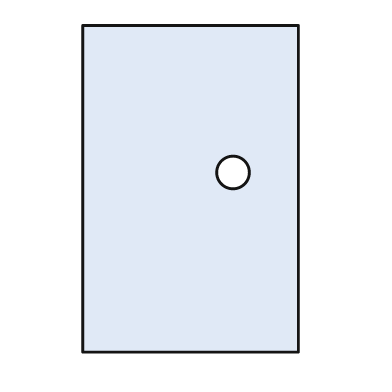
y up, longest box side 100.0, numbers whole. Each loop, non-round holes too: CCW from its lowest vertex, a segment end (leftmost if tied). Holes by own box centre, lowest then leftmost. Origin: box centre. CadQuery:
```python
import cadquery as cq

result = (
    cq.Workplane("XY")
    .moveTo(-33.0, -50.0)
    .lineTo(33.0, -50.0)
    .lineTo(33.0, 50.0)
    .lineTo(-33.0, 50.0)
    .close()
    .moveTo(13.0, 5.0)
    .circle(5.0)
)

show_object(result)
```